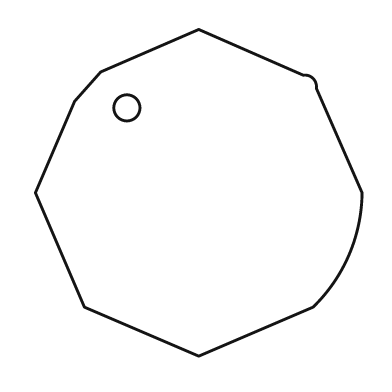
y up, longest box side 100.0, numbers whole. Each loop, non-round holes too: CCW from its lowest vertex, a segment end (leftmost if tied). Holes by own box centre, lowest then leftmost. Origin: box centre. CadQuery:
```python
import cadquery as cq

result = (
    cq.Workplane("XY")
    .moveTo(0.0, -50.0)
    .lineTo(35.0, -35.0)
    .threePointArc((46.0, -19.0), (50.0, 0.0))
    .lineTo(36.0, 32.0)
    .threePointArc((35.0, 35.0), (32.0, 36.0))
    .lineTo(0.0, 50.0)
    .lineTo(-30.0, 37.0)
    .lineTo(-38.0, 28.0)
    .lineTo(-50.0, 0.0)
    .lineTo(-35.0, -35.0)
    .close()
    .moveTo(-22.0, 26.0)
    .circle(4.0)
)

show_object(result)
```